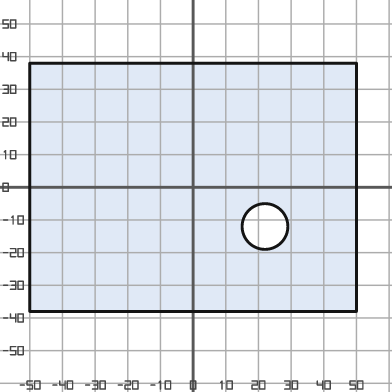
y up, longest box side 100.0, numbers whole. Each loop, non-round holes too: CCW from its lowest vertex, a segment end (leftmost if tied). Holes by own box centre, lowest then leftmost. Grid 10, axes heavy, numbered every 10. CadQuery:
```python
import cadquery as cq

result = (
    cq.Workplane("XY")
    .moveTo(-50.0, -38.0)
    .lineTo(50.0, -38.0)
    .lineTo(50.0, 38.0)
    .lineTo(-50.0, 38.0)
    .close()
    .moveTo(22.0, -12.0)
    .circle(7.0)
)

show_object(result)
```